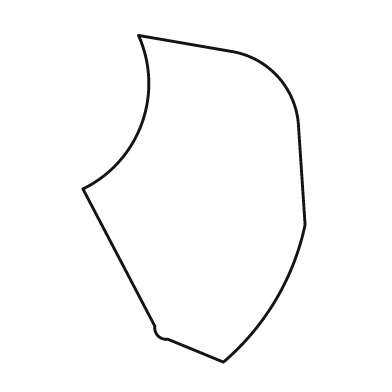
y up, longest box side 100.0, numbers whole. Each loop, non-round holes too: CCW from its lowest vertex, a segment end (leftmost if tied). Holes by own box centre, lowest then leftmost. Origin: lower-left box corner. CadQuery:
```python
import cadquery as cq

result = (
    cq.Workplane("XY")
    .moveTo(43.0, 0.0)
    .threePointArc((59.0, 19.0), (68.0, 42.0))
    .lineTo(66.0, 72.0)
    .threePointArc((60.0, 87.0), (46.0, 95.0))
    .lineTo(17.0, 100.0)
    .threePointArc((18.0, 73.0), (0.0, 53.0))
    .lineTo(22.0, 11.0)
    .threePointArc((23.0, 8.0), (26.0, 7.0))
    .close()
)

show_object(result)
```